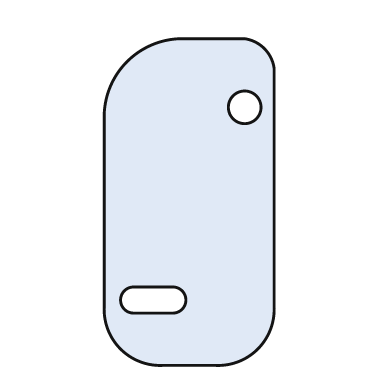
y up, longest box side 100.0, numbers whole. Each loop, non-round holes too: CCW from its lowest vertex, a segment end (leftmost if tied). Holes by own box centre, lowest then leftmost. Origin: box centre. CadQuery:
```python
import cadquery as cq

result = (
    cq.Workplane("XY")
    .moveTo(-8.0, -50.0)
    .lineTo(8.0, -50.0)
    .threePointArc((21.0, -45.0), (26.0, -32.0))
    .lineTo(26.0, 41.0)
    .threePointArc((23.0, 47.0), (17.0, 50.0))
    .lineTo(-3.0, 50.0)
    .threePointArc((-19.0, 43.0), (-26.0, 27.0))
    .lineTo(-26.0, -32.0)
    .threePointArc((-21.0, -45.0), (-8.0, -50.0))
    .close()
    .moveTo(-17.0, -34.0)
    .lineTo(-5.0, -34.0)
    .threePointArc((-1.0, -30.0), (-5.0, -26.0))
    .lineTo(-17.0, -26.0)
    .threePointArc((-21.0, -30.0), (-17.0, -34.0))
    .close()
    .moveTo(17.0, 29.0)
    .circle(5.0)
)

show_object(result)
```